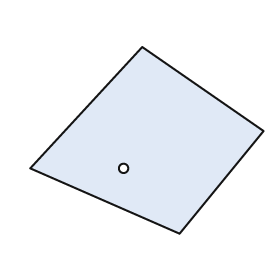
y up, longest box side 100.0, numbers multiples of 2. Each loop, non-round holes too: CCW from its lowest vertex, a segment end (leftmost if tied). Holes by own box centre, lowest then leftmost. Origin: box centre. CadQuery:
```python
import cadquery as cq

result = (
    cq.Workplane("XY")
    .moveTo(14.0, -40.0)
    .lineTo(50.0, 4.0)
    .lineTo(-2.0, 40.0)
    .lineTo(-50.0, -12.0)
    .close()
    .moveTo(-10.0, -12.0)
    .circle(2.0)
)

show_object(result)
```